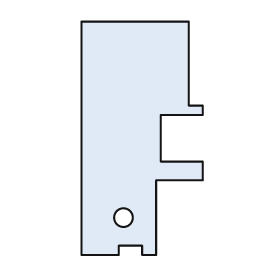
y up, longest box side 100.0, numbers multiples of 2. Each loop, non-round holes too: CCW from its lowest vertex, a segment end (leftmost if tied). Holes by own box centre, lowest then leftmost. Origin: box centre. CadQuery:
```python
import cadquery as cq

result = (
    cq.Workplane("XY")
    .moveTo(-26.0, -50.0)
    .lineTo(-10.0, -50.0)
    .lineTo(-10.0, -46.0)
    .lineTo(0.0, -46.0)
    .lineTo(0.0, -50.0)
    .lineTo(6.0, -50.0)
    .lineTo(6.0, -18.0)
    .lineTo(26.0, -18.0)
    .lineTo(26.0, -10.0)
    .lineTo(8.0, -10.0)
    .lineTo(8.0, 10.0)
    .lineTo(26.0, 10.0)
    .lineTo(26.0, 14.0)
    .lineTo(20.0, 14.0)
    .lineTo(20.0, 50.0)
    .lineTo(-26.0, 50.0)
    .close()
    .moveTo(-8.0, -34.0)
    .circle(4.0)
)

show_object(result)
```